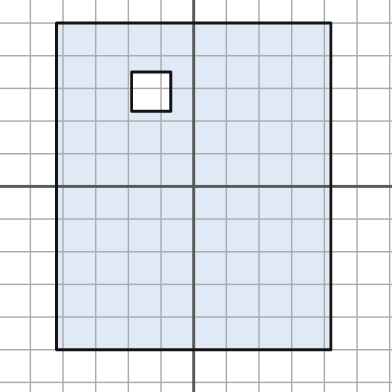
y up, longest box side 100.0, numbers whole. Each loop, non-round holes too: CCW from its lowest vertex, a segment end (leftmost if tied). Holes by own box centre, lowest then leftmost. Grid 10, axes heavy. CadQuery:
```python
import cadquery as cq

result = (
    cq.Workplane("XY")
    .moveTo(-42.0, -50.0)
    .lineTo(42.0, -50.0)
    .lineTo(42.0, 50.0)
    .lineTo(-42.0, 50.0)
    .close()
    .moveTo(-19.0, 23.0)
    .lineTo(-7.0, 23.0)
    .lineTo(-7.0, 35.0)
    .lineTo(-19.0, 35.0)
    .close()
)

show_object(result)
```